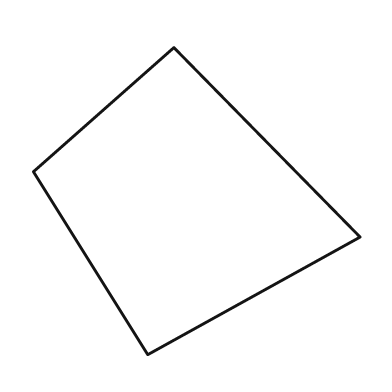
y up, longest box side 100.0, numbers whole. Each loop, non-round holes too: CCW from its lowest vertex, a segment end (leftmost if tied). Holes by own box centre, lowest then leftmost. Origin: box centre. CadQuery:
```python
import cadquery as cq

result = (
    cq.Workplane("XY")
    .moveTo(-15.0, -47.0)
    .lineTo(50.0, -11.0)
    .lineTo(-7.0, 47.0)
    .lineTo(-50.0, 9.0)
    .close()
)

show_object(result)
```